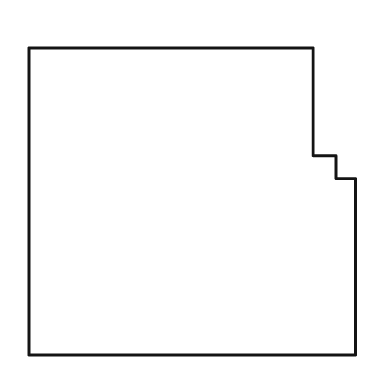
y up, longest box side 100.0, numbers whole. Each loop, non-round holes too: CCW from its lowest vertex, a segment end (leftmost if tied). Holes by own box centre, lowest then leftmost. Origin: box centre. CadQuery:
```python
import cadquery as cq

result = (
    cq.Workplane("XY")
    .moveTo(-50.0, -47.0)
    .lineTo(50.0, -47.0)
    .lineTo(50.0, 7.0)
    .lineTo(44.0, 7.0)
    .lineTo(44.0, 14.0)
    .lineTo(37.0, 14.0)
    .lineTo(37.0, 47.0)
    .lineTo(-50.0, 47.0)
    .close()
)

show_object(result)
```